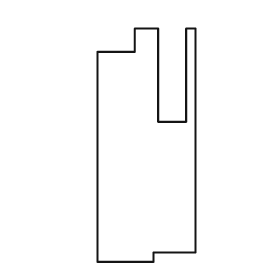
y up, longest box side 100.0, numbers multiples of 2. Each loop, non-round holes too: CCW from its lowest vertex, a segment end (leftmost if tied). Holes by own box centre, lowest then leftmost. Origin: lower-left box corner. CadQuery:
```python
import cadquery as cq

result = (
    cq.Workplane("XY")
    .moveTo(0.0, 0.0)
    .lineTo(24.0, 0.0)
    .lineTo(24.0, 4.0)
    .lineTo(42.0, 4.0)
    .lineTo(42.0, 100.0)
    .lineTo(38.0, 100.0)
    .lineTo(38.0, 60.0)
    .lineTo(26.0, 60.0)
    .lineTo(26.0, 100.0)
    .lineTo(16.0, 100.0)
    .lineTo(16.0, 90.0)
    .lineTo(0.0, 90.0)
    .close()
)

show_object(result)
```